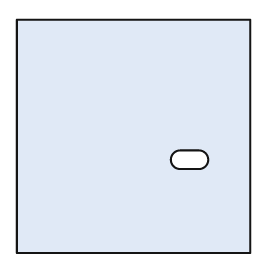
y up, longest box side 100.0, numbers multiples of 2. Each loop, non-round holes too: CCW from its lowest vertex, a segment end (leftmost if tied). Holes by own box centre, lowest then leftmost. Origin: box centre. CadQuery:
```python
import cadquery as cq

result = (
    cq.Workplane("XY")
    .moveTo(-50.0, -50.0)
    .lineTo(50.0, -50.0)
    .lineTo(50.0, 50.0)
    .lineTo(-50.0, 50.0)
    .close()
    .moveTo(20.0, -14.0)
    .lineTo(28.0, -14.0)
    .threePointArc((32.0, -10.0), (28.0, -6.0))
    .lineTo(20.0, -6.0)
    .threePointArc((16.0, -10.0), (20.0, -14.0))
    .close()
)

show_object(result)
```